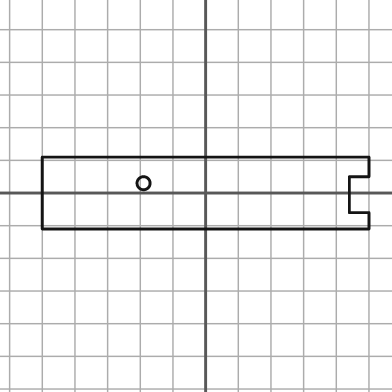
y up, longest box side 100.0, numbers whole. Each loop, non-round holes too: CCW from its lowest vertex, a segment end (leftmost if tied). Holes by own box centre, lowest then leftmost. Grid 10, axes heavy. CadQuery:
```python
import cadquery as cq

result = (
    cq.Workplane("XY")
    .moveTo(-50.0, -11.0)
    .lineTo(50.0, -11.0)
    .lineTo(50.0, -6.0)
    .lineTo(44.0, -6.0)
    .lineTo(44.0, 5.0)
    .lineTo(50.0, 5.0)
    .lineTo(50.0, 11.0)
    .lineTo(-50.0, 11.0)
    .close()
    .moveTo(-19.0, 3.0)
    .circle(2.0)
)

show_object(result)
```